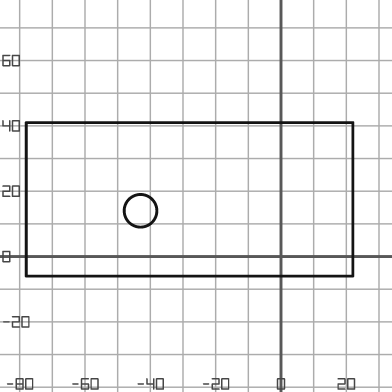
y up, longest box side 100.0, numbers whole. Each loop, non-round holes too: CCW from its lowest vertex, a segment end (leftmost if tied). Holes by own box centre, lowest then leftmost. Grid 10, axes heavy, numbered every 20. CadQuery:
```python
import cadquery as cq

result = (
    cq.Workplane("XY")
    .moveTo(-78.0, -6.0)
    .lineTo(22.0, -6.0)
    .lineTo(22.0, 41.0)
    .lineTo(-78.0, 41.0)
    .close()
    .moveTo(-43.0, 14.0)
    .circle(5.0)
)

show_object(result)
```